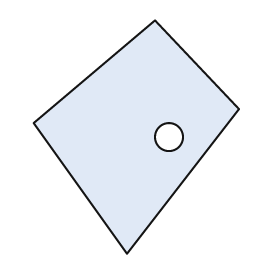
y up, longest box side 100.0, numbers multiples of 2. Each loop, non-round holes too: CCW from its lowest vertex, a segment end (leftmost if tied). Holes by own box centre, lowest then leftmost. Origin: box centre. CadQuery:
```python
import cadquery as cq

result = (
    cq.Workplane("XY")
    .moveTo(-4.0, -50.0)
    .lineTo(44.0, 12.0)
    .lineTo(8.0, 50.0)
    .lineTo(-44.0, 6.0)
    .close()
    .moveTo(14.0, 0.0)
    .circle(6.0)
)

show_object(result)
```